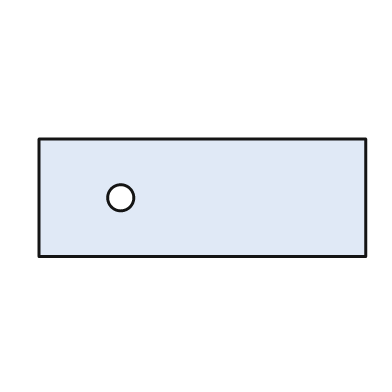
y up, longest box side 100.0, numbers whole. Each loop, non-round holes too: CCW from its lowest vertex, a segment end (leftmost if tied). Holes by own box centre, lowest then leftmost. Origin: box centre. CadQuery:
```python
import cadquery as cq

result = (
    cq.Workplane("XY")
    .moveTo(-50.0, -18.0)
    .lineTo(50.0, -18.0)
    .lineTo(50.0, 18.0)
    .lineTo(-50.0, 18.0)
    .close()
    .moveTo(-25.0, 0.0)
    .circle(4.0)
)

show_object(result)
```